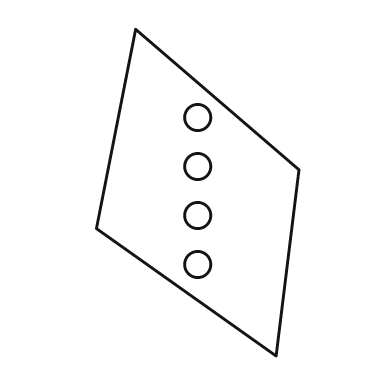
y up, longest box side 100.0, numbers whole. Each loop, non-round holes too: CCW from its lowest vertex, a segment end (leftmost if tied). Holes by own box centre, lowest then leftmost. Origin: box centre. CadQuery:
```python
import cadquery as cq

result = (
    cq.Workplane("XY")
    .moveTo(24.0, -50.0)
    .lineTo(31.0, 7.0)
    .lineTo(-19.0, 50.0)
    .lineTo(-31.0, -11.0)
    .close()
    .moveTo(0.0, -22.0)
    .circle(4.0)
    .moveTo(0.0, -7.0)
    .circle(4.0)
    .moveTo(0.0, 8.0)
    .circle(4.0)
    .moveTo(0.0, 23.0)
    .circle(4.0)
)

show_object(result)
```